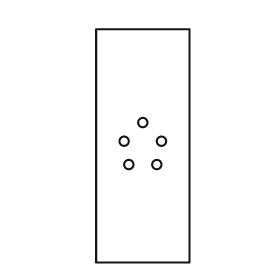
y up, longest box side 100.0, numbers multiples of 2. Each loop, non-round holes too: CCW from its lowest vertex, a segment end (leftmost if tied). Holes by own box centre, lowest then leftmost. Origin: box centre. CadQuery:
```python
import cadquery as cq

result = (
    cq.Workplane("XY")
    .moveTo(-20.0, -50.0)
    .lineTo(20.0, -50.0)
    .lineTo(20.0, 50.0)
    .lineTo(-20.0, 50.0)
    .close()
    .moveTo(-6.0, -8.0)
    .circle(2.0)
    .moveTo(6.0, -8.0)
    .circle(2.0)
    .moveTo(-8.0, 2.0)
    .circle(2.0)
    .moveTo(8.0, 2.0)
    .circle(2.0)
    .moveTo(0.0, 10.0)
    .circle(2.0)
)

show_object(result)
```